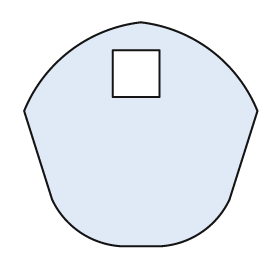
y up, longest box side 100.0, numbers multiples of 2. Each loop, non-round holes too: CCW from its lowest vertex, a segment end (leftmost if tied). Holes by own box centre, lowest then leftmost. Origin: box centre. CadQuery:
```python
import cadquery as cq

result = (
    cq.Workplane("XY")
    .moveTo(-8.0, -48.0)
    .lineTo(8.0, -48.0)
    .threePointArc((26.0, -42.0), (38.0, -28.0))
    .lineTo(50.0, 10.0)
    .threePointArc((30.0, 36.0), (0.0, 48.0))
    .threePointArc((-30.0, 36.0), (-50.0, 10.0))
    .lineTo(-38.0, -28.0)
    .threePointArc((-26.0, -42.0), (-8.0, -48.0))
    .close()
    .moveTo(-12.0, 16.0)
    .lineTo(8.0, 16.0)
    .lineTo(8.0, 36.0)
    .lineTo(-12.0, 36.0)
    .close()
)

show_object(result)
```